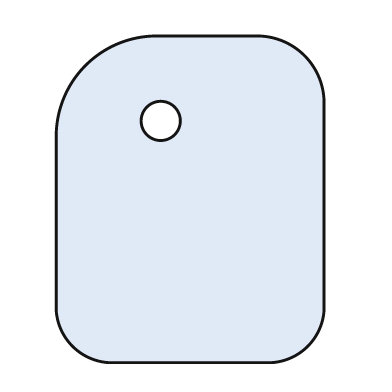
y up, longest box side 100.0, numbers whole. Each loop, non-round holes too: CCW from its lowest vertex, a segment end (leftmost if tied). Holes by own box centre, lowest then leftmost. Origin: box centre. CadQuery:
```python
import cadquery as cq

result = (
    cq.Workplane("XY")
    .moveTo(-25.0, -50.0)
    .lineTo(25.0, -50.0)
    .threePointArc((36.0, -45.0), (41.0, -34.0))
    .lineTo(41.0, 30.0)
    .threePointArc((35.0, 44.0), (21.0, 50.0))
    .lineTo(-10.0, 50.0)
    .threePointArc((-32.0, 41.0), (-41.0, 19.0))
    .lineTo(-41.0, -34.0)
    .threePointArc((-36.0, -45.0), (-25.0, -50.0))
    .close()
    .moveTo(-9.0, 24.0)
    .circle(6.0)
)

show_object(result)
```